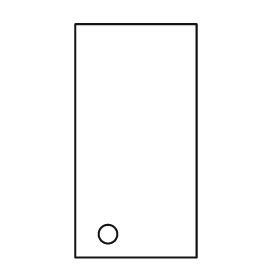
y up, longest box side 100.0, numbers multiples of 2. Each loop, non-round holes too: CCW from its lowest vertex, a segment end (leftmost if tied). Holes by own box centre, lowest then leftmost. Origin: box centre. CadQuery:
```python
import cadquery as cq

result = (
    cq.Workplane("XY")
    .moveTo(-26.0, -50.0)
    .lineTo(26.0, -50.0)
    .lineTo(26.0, 50.0)
    .lineTo(-26.0, 50.0)
    .close()
    .moveTo(-12.0, -40.0)
    .circle(4.0)
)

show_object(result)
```